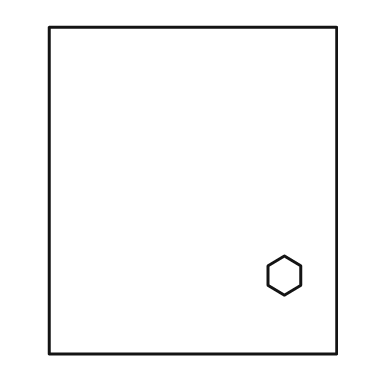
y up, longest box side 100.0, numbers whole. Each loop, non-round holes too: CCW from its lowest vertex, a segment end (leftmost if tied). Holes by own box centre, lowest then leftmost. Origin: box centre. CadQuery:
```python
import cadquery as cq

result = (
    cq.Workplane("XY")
    .moveTo(-44.0, -50.0)
    .lineTo(44.0, -50.0)
    .lineTo(44.0, 50.0)
    .lineTo(-44.0, 50.0)
    .close()
    .moveTo(28.0, -32.0)
    .lineTo(33.0, -29.0)
    .lineTo(33.0, -23.0)
    .lineTo(28.0, -20.0)
    .lineTo(23.0, -23.0)
    .lineTo(23.0, -29.0)
    .close()
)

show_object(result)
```